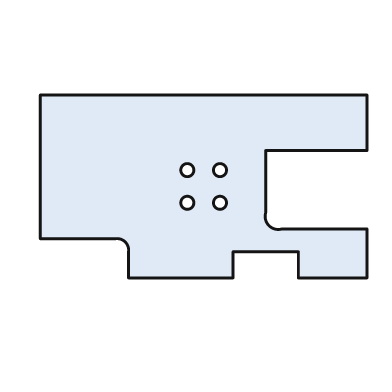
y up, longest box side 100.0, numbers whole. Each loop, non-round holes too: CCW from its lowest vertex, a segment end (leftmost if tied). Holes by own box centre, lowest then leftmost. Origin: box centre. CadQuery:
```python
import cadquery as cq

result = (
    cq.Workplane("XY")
    .moveTo(-23.0, -28.0)
    .lineTo(9.0, -28.0)
    .lineTo(9.0, -20.0)
    .lineTo(29.0, -20.0)
    .lineTo(29.0, -28.0)
    .lineTo(50.0, -28.0)
    .lineTo(50.0, -13.0)
    .lineTo(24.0, -13.0)
    .threePointArc((20.0, -12.0), (19.0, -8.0))
    .lineTo(19.0, 11.0)
    .lineTo(50.0, 11.0)
    .lineTo(50.0, 28.0)
    .lineTo(-50.0, 28.0)
    .lineTo(-50.0, -16.0)
    .lineTo(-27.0, -16.0)
    .threePointArc((-24.0, -17.0), (-23.0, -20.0))
    .close()
    .moveTo(-5.0, -5.0)
    .circle(2.0)
    .moveTo(5.0, -5.0)
    .circle(2.0)
    .moveTo(-5.0, 5.0)
    .circle(2.0)
    .moveTo(5.0, 5.0)
    .circle(2.0)
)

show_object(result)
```